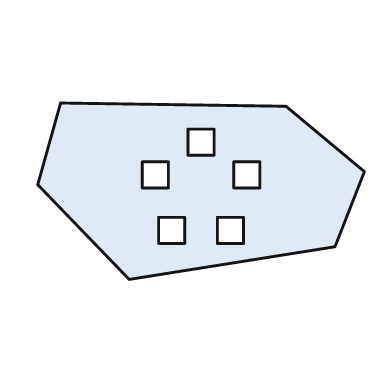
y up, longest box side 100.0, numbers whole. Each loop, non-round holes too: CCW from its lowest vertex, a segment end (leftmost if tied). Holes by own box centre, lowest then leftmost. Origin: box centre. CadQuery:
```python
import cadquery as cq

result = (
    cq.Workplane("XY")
    .moveTo(-22.0, -27.0)
    .lineTo(41.0, -17.0)
    .lineTo(50.0, 6.0)
    .lineTo(26.0, 26.0)
    .lineTo(-43.0, 27.0)
    .lineTo(-50.0, 2.0)
    .close()
    .moveTo(-13.0, -16.0)
    .lineTo(-5.0, -16.0)
    .lineTo(-5.0, -8.0)
    .lineTo(-13.0, -8.0)
    .close()
    .moveTo(5.0, -16.0)
    .lineTo(13.0, -16.0)
    .lineTo(13.0, -8.0)
    .lineTo(5.0, -8.0)
    .close()
    .moveTo(-18.0, 1.0)
    .lineTo(-10.0, 1.0)
    .lineTo(-10.0, 9.0)
    .lineTo(-18.0, 9.0)
    .close()
    .moveTo(10.0, 1.0)
    .lineTo(18.0, 1.0)
    .lineTo(18.0, 9.0)
    .lineTo(10.0, 9.0)
    .close()
    .moveTo(-4.0, 11.0)
    .lineTo(4.0, 11.0)
    .lineTo(4.0, 19.0)
    .lineTo(-4.0, 19.0)
    .close()
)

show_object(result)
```